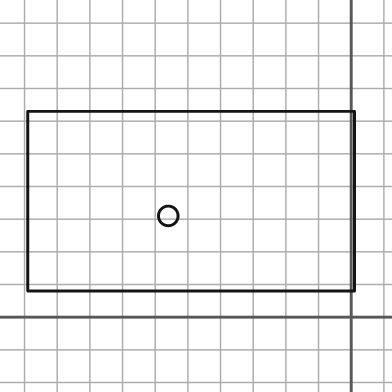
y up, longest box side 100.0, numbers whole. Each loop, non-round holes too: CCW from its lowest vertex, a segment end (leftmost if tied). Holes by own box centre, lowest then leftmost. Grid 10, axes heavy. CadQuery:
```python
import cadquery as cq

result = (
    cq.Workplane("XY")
    .moveTo(-99.0, 8.0)
    .lineTo(1.0, 8.0)
    .lineTo(1.0, 63.0)
    .lineTo(-99.0, 63.0)
    .close()
    .moveTo(-56.0, 31.0)
    .circle(3.0)
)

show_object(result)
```